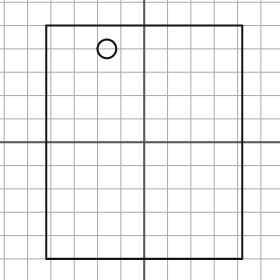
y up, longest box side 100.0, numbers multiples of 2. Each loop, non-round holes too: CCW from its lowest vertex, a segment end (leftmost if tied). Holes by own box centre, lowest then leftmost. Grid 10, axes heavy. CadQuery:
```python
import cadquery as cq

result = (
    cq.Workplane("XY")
    .moveTo(-42.0, -50.0)
    .lineTo(42.0, -50.0)
    .lineTo(42.0, 50.0)
    .lineTo(-42.0, 50.0)
    .close()
    .moveTo(-16.0, 40.0)
    .circle(4.0)
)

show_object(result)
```